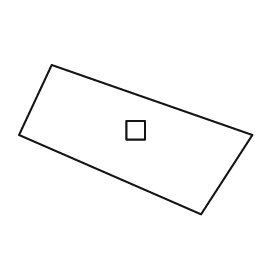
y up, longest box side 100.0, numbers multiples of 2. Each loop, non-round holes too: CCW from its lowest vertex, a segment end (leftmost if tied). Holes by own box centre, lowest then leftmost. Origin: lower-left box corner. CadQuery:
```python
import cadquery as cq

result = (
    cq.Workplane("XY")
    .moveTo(78.0, 0.0)
    .lineTo(100.0, 34.0)
    .lineTo(14.0, 64.0)
    .lineTo(0.0, 34.0)
    .close()
    .moveTo(46.0, 32.0)
    .lineTo(54.0, 32.0)
    .lineTo(54.0, 40.0)
    .lineTo(46.0, 40.0)
    .close()
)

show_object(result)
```